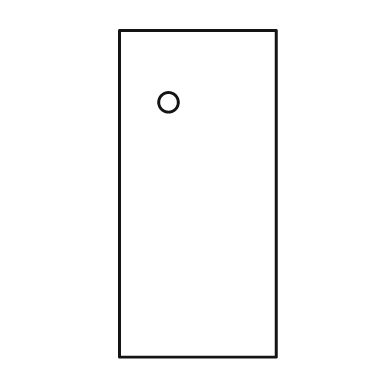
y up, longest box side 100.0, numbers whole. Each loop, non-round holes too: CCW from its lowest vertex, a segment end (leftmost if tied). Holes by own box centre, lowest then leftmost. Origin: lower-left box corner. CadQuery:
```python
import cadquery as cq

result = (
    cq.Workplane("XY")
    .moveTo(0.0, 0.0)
    .lineTo(48.0, 0.0)
    .lineTo(48.0, 100.0)
    .lineTo(0.0, 100.0)
    .close()
    .moveTo(15.0, 78.0)
    .circle(3.0)
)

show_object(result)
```